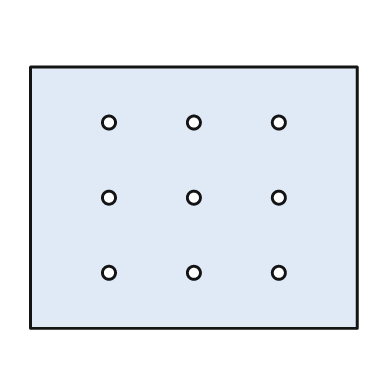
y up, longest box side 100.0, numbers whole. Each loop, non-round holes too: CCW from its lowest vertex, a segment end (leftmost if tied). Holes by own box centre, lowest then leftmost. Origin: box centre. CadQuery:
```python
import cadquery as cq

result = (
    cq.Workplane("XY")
    .moveTo(-50.0, -40.0)
    .lineTo(50.0, -40.0)
    .lineTo(50.0, 40.0)
    .lineTo(-50.0, 40.0)
    .close()
    .moveTo(-26.0, -23.0)
    .circle(2.0)
    .moveTo(0.0, -23.0)
    .circle(2.0)
    .moveTo(26.0, -23.0)
    .circle(2.0)
    .moveTo(-26.0, 0.0)
    .circle(2.0)
    .moveTo(0.0, 0.0)
    .circle(2.0)
    .moveTo(26.0, 0.0)
    .circle(2.0)
    .moveTo(-26.0, 23.0)
    .circle(2.0)
    .moveTo(0.0, 23.0)
    .circle(2.0)
    .moveTo(26.0, 23.0)
    .circle(2.0)
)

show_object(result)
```